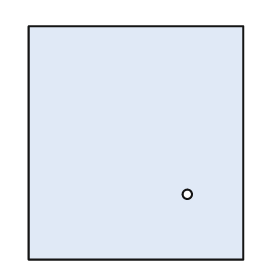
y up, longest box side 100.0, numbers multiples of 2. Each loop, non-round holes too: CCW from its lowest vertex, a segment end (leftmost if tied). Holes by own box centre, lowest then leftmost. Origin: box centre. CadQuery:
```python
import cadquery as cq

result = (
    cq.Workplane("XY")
    .moveTo(-46.0, -50.0)
    .lineTo(46.0, -50.0)
    .lineTo(46.0, 50.0)
    .lineTo(-46.0, 50.0)
    .close()
    .moveTo(22.0, -22.0)
    .circle(2.0)
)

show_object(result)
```